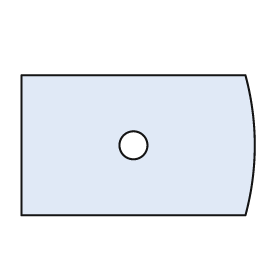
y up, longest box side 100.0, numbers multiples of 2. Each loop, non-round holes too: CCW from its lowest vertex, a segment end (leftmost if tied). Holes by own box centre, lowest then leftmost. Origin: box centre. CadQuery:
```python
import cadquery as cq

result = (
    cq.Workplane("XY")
    .moveTo(-50.0, -30.0)
    .lineTo(46.0, -30.0)
    .threePointArc((50.0, 0.0), (46.0, 30.0))
    .lineTo(-50.0, 30.0)
    .close()
    .moveTo(-2.0, 0.0)
    .circle(6.0)
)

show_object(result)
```